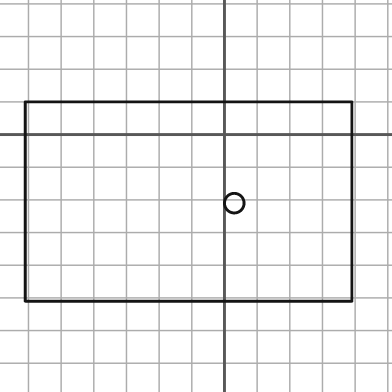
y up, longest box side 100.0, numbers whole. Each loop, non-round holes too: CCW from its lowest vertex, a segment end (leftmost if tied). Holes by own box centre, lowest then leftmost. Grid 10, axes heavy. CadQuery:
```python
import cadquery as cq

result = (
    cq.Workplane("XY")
    .moveTo(-61.0, -51.0)
    .lineTo(39.0, -51.0)
    .lineTo(39.0, 10.0)
    .lineTo(-61.0, 10.0)
    .close()
    .moveTo(3.0, -21.0)
    .circle(3.0)
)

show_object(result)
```